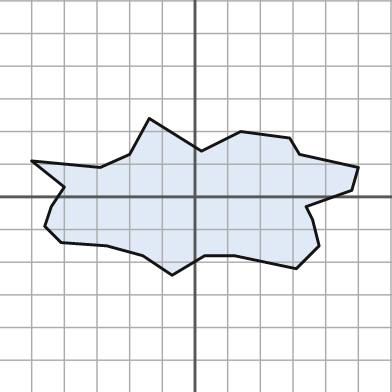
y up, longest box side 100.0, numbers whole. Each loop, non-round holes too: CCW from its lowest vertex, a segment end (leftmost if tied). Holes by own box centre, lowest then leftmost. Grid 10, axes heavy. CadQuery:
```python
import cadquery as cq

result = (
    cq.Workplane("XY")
    .moveTo(-7.0, -24.0)
    .lineTo(3.0, -18.0)
    .lineTo(12.0, -18.0)
    .lineTo(31.0, -22.0)
    .lineTo(38.0, -15.0)
    .lineTo(36.0, -7.0)
    .lineTo(34.0, -3.0)
    .lineTo(48.0, 2.0)
    .lineTo(50.0, 9.0)
    .lineTo(32.0, 13.0)
    .lineTo(29.0, 18.0)
    .lineTo(14.0, 20.0)
    .lineTo(2.0, 14.0)
    .lineTo(-14.0, 24.0)
    .lineTo(-20.0, 13.0)
    .lineTo(-29.0, 9.0)
    .lineTo(-50.0, 11.0)
    .lineTo(-40.0, 3.0)
    .lineTo(-44.0, -3.0)
    .lineTo(-46.0, -9.0)
    .lineTo(-41.0, -14.0)
    .lineTo(-27.0, -15.0)
    .lineTo(-16.0, -18.0)
    .close()
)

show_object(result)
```